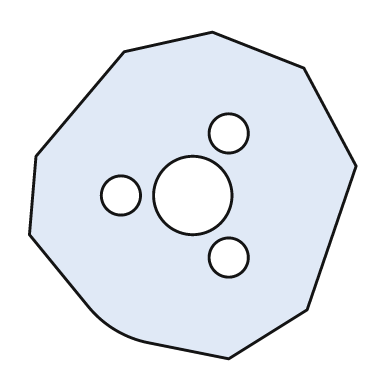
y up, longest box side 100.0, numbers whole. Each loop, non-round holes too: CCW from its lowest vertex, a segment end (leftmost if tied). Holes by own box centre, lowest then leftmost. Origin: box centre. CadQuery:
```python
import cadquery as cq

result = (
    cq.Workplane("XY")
    .moveTo(11.0, -50.0)
    .lineTo(35.0, -35.0)
    .lineTo(50.0, 9.0)
    .lineTo(34.0, 39.0)
    .lineTo(6.0, 50.0)
    .lineTo(-21.0, 44.0)
    .lineTo(-48.0, 12.0)
    .lineTo(-50.0, -12.0)
    .lineTo(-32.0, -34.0)
    .threePointArc((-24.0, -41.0), (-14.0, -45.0))
    .close()
    .moveTo(11.0, -19.0)
    .circle(6.0)
    .moveTo(-22.0, 0.0)
    .circle(6.0)
    .moveTo(0.0, 0.0)
    .circle(12.0)
    .moveTo(11.0, 19.0)
    .circle(6.0)
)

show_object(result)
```